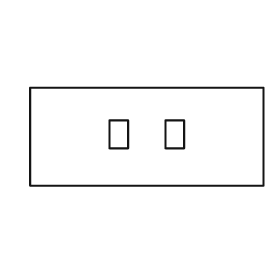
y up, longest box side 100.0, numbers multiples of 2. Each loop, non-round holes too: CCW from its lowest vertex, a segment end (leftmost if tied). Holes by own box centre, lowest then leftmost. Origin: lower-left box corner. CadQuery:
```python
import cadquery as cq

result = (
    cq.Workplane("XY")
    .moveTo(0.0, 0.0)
    .lineTo(100.0, 0.0)
    .lineTo(100.0, 42.0)
    .lineTo(0.0, 42.0)
    .close()
    .moveTo(34.0, 16.0)
    .lineTo(42.0, 16.0)
    .lineTo(42.0, 28.0)
    .lineTo(34.0, 28.0)
    .close()
    .moveTo(58.0, 16.0)
    .lineTo(66.0, 16.0)
    .lineTo(66.0, 28.0)
    .lineTo(58.0, 28.0)
    .close()
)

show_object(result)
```